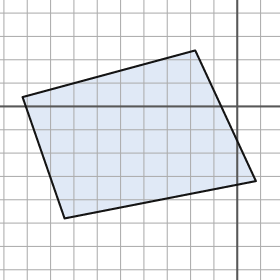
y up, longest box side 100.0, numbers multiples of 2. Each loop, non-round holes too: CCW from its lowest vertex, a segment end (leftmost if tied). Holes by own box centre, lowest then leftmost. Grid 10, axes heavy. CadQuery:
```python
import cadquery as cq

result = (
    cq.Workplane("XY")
    .moveTo(-74.0, -48.0)
    .lineTo(8.0, -32.0)
    .lineTo(-18.0, 24.0)
    .lineTo(-92.0, 4.0)
    .close()
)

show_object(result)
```